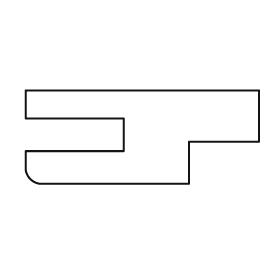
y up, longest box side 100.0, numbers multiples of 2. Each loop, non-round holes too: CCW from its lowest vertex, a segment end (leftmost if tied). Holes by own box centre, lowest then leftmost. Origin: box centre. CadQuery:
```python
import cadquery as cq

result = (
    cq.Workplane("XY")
    .moveTo(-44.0, -20.0)
    .lineTo(20.0, -20.0)
    .lineTo(20.0, -2.0)
    .lineTo(50.0, -2.0)
    .lineTo(50.0, 20.0)
    .lineTo(-50.0, 20.0)
    .lineTo(-50.0, 8.0)
    .lineTo(-8.0, 8.0)
    .lineTo(-8.0, -6.0)
    .lineTo(-50.0, -6.0)
    .lineTo(-50.0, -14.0)
    .threePointArc((-48.0, -18.0), (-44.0, -20.0))
    .close()
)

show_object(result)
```